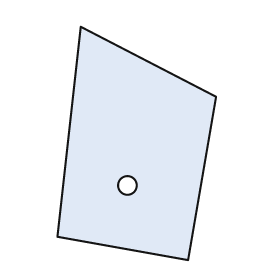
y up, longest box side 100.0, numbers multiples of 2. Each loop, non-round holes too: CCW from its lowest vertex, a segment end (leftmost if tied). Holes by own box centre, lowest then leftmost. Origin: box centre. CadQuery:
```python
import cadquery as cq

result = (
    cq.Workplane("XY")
    .moveTo(22.0, -50.0)
    .lineTo(34.0, 20.0)
    .lineTo(-24.0, 50.0)
    .lineTo(-34.0, -40.0)
    .close()
    .moveTo(-4.0, -18.0)
    .circle(4.0)
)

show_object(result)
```